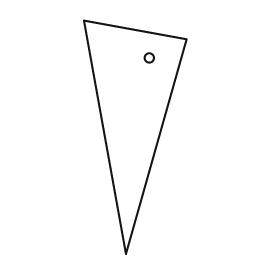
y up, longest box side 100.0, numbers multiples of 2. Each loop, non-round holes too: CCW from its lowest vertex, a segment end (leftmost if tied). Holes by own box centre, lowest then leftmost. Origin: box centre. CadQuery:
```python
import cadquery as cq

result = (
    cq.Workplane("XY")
    .moveTo(-4.0, -50.0)
    .lineTo(22.0, 42.0)
    .lineTo(-22.0, 50.0)
    .close()
    .moveTo(6.0, 34.0)
    .circle(2.0)
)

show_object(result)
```